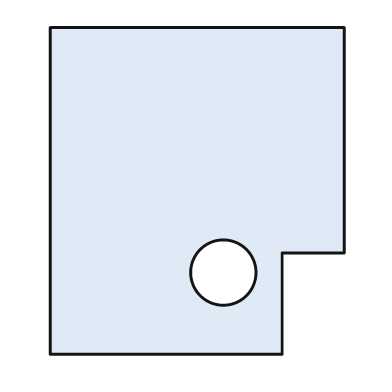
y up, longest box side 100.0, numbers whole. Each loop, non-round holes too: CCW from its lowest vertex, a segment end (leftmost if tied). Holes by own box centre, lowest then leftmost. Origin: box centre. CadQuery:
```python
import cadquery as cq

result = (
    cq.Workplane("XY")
    .moveTo(-45.0, -50.0)
    .lineTo(26.0, -50.0)
    .lineTo(26.0, -19.0)
    .lineTo(45.0, -19.0)
    .lineTo(45.0, 50.0)
    .lineTo(-45.0, 50.0)
    .close()
    .moveTo(8.0, -25.0)
    .circle(10.0)
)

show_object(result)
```